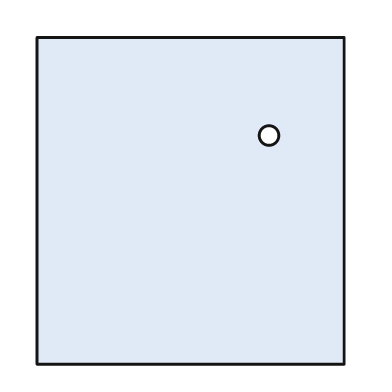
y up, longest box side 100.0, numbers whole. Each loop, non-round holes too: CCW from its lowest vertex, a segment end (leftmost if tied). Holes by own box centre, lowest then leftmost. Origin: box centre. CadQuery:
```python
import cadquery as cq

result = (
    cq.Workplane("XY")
    .moveTo(-47.0, -50.0)
    .lineTo(47.0, -50.0)
    .lineTo(47.0, 50.0)
    .lineTo(-47.0, 50.0)
    .close()
    .moveTo(24.0, 20.0)
    .circle(3.0)
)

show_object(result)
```